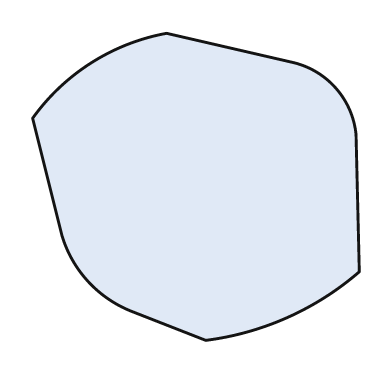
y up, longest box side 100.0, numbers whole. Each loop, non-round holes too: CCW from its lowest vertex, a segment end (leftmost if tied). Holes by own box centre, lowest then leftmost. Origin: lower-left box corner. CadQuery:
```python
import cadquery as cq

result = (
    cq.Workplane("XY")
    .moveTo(53.0, 0.0)
    .threePointArc((78.0, 7.0), (100.0, 21.0))
    .lineTo(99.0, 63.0)
    .threePointArc((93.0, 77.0), (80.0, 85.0))
    .lineTo(41.0, 94.0)
    .threePointArc((18.0, 85.0), (0.0, 68.0))
    .lineTo(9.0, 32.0)
    .threePointArc((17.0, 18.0), (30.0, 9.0))
    .close()
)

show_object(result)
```